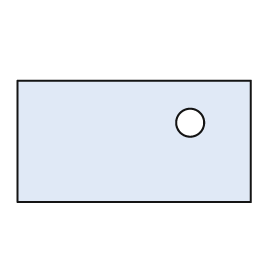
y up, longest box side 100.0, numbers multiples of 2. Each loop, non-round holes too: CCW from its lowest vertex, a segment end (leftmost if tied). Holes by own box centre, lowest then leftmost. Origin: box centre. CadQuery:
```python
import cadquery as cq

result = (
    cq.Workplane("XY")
    .moveTo(-50.0, -26.0)
    .lineTo(50.0, -26.0)
    .lineTo(50.0, 26.0)
    .lineTo(-50.0, 26.0)
    .close()
    .moveTo(24.0, 8.0)
    .circle(6.0)
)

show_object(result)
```